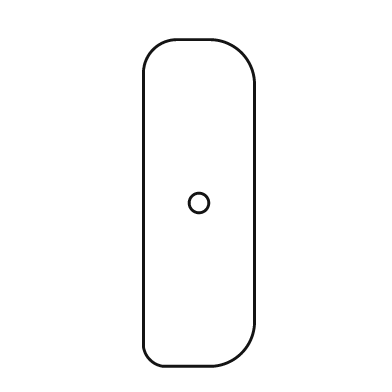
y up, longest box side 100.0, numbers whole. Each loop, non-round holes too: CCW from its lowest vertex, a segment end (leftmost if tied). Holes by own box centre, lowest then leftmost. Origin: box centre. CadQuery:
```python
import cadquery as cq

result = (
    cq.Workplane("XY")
    .moveTo(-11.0, -50.0)
    .lineTo(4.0, -50.0)
    .threePointArc((13.0, -46.0), (17.0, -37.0))
    .lineTo(17.0, 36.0)
    .threePointArc((13.0, 46.0), (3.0, 50.0))
    .lineTo(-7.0, 50.0)
    .threePointArc((-14.0, 47.0), (-17.0, 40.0))
    .lineTo(-17.0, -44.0)
    .threePointArc((-15.0, -48.0), (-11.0, -50.0))
    .close()
    .moveTo(0.0, 0.0)
    .circle(3.0)
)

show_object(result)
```